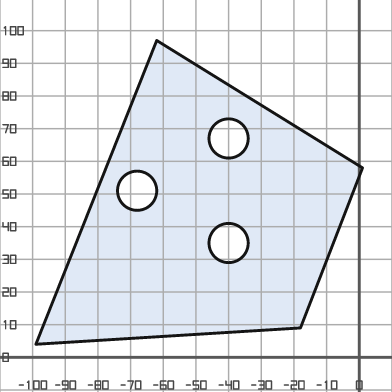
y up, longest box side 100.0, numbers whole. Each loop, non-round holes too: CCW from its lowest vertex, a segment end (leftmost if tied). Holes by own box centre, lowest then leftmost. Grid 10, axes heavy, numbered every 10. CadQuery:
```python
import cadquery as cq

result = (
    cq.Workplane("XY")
    .moveTo(-99.0, 4.0)
    .lineTo(-18.0, 9.0)
    .lineTo(1.0, 58.0)
    .lineTo(-62.0, 97.0)
    .close()
    .moveTo(-40.0, 35.0)
    .circle(6.0)
    .moveTo(-68.0, 51.0)
    .circle(6.0)
    .moveTo(-40.0, 67.0)
    .circle(6.0)
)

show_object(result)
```